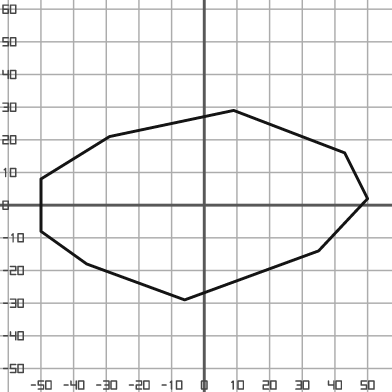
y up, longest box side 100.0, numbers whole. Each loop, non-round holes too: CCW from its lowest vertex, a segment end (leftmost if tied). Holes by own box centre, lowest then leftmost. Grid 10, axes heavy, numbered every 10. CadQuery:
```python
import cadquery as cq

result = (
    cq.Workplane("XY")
    .moveTo(-6.0, -29.0)
    .lineTo(35.0, -14.0)
    .lineTo(50.0, 2.0)
    .lineTo(43.0, 16.0)
    .lineTo(9.0, 29.0)
    .lineTo(-29.0, 21.0)
    .lineTo(-50.0, 8.0)
    .lineTo(-50.0, -8.0)
    .lineTo(-36.0, -18.0)
    .close()
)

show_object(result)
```